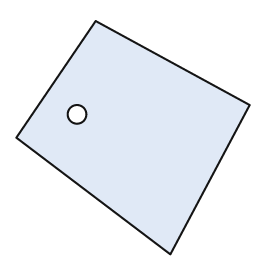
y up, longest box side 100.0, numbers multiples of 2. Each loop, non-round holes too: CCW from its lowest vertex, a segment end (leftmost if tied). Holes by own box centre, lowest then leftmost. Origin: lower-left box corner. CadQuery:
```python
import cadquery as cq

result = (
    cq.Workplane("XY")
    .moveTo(66.0, 0.0)
    .lineTo(100.0, 64.0)
    .lineTo(34.0, 100.0)
    .lineTo(0.0, 50.0)
    .close()
    .moveTo(26.0, 60.0)
    .circle(4.0)
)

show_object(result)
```